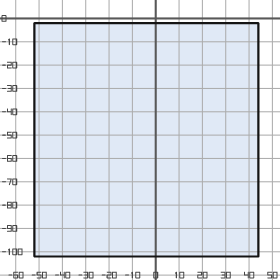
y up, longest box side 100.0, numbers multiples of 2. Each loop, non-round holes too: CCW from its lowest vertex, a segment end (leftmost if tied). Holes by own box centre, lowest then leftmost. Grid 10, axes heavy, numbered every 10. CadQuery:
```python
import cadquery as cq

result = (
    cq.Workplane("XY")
    .moveTo(-52.0, -102.0)
    .lineTo(44.0, -102.0)
    .lineTo(44.0, -2.0)
    .lineTo(-52.0, -2.0)
    .close()
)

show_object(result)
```